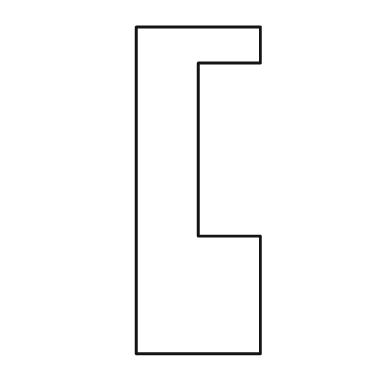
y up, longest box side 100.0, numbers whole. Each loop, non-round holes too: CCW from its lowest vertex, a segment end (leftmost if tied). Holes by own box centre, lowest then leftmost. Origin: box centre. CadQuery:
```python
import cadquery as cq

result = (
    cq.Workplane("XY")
    .moveTo(-19.0, -50.0)
    .lineTo(19.0, -50.0)
    .lineTo(19.0, -14.0)
    .lineTo(0.0, -14.0)
    .lineTo(0.0, 39.0)
    .lineTo(19.0, 39.0)
    .lineTo(19.0, 50.0)
    .lineTo(-19.0, 50.0)
    .close()
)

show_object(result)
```